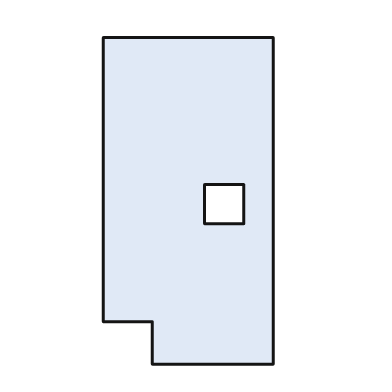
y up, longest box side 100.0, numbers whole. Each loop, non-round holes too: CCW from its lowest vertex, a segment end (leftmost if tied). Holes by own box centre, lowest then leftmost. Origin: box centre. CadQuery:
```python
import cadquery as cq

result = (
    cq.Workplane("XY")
    .moveTo(-11.0, -50.0)
    .lineTo(26.0, -50.0)
    .lineTo(26.0, 50.0)
    .lineTo(-26.0, 50.0)
    .lineTo(-26.0, -37.0)
    .lineTo(-11.0, -37.0)
    .close()
    .moveTo(5.0, -7.0)
    .lineTo(17.0, -7.0)
    .lineTo(17.0, 5.0)
    .lineTo(5.0, 5.0)
    .close()
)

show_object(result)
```